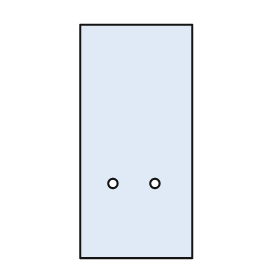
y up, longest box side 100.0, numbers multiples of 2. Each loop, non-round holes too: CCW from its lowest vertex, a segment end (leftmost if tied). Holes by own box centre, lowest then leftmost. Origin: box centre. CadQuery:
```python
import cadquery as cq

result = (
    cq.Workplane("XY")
    .moveTo(-24.0, -50.0)
    .lineTo(24.0, -50.0)
    .lineTo(24.0, 50.0)
    .lineTo(-24.0, 50.0)
    .close()
    .moveTo(-10.0, -18.0)
    .circle(2.0)
    .moveTo(8.0, -18.0)
    .circle(2.0)
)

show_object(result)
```